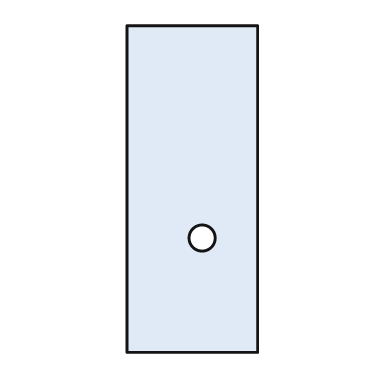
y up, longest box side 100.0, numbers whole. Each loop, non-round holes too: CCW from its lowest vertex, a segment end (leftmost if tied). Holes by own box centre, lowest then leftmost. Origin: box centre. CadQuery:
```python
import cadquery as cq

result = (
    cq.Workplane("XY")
    .moveTo(-20.0, -50.0)
    .lineTo(20.0, -50.0)
    .lineTo(20.0, 50.0)
    .lineTo(-20.0, 50.0)
    .close()
    .moveTo(3.0, -15.0)
    .circle(4.0)
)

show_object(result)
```